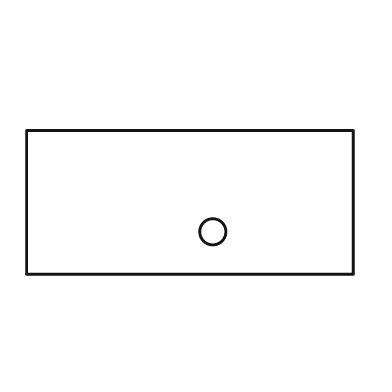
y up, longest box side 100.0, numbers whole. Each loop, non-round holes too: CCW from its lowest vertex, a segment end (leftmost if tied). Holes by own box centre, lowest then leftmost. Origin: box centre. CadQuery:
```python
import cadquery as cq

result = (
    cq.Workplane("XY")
    .moveTo(-50.0, -22.0)
    .lineTo(50.0, -22.0)
    .lineTo(50.0, 22.0)
    .lineTo(-50.0, 22.0)
    .close()
    .moveTo(7.0, -9.0)
    .circle(4.0)
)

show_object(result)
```